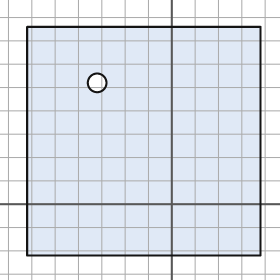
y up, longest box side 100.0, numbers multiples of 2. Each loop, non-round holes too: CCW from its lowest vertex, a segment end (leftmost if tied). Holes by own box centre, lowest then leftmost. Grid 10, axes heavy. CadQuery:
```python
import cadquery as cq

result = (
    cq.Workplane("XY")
    .moveTo(-62.0, -22.0)
    .lineTo(38.0, -22.0)
    .lineTo(38.0, 76.0)
    .lineTo(-62.0, 76.0)
    .close()
    .moveTo(-32.0, 52.0)
    .circle(4.0)
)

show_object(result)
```